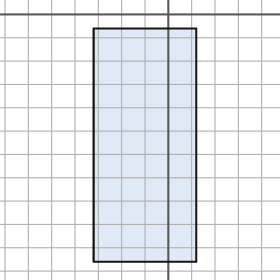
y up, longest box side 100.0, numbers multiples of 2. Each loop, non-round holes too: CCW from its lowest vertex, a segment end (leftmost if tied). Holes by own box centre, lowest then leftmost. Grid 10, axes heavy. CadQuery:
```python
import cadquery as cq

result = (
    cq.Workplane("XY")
    .moveTo(-32.0, -106.0)
    .lineTo(12.0, -106.0)
    .lineTo(12.0, -6.0)
    .lineTo(-32.0, -6.0)
    .close()
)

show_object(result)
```